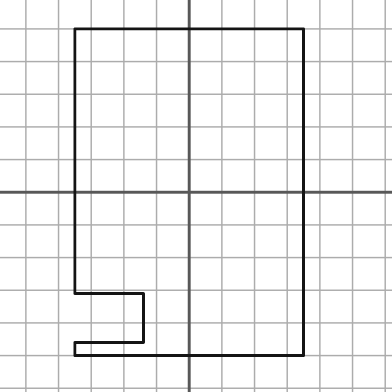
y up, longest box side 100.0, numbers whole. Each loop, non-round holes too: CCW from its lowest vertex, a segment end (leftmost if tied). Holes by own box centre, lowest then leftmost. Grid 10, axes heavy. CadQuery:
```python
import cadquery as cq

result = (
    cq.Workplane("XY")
    .moveTo(-35.0, -50.0)
    .lineTo(35.0, -50.0)
    .lineTo(35.0, 50.0)
    .lineTo(-35.0, 50.0)
    .lineTo(-35.0, -31.0)
    .lineTo(-14.0, -31.0)
    .lineTo(-14.0, -46.0)
    .lineTo(-35.0, -46.0)
    .close()
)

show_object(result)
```